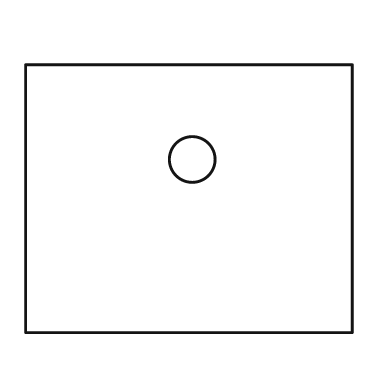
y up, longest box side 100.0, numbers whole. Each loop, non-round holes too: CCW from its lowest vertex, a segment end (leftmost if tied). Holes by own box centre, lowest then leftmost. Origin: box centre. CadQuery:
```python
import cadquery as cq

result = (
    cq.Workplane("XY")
    .moveTo(-50.0, -41.0)
    .lineTo(50.0, -41.0)
    .lineTo(50.0, 41.0)
    .lineTo(-50.0, 41.0)
    .close()
    .moveTo(1.0, 12.0)
    .circle(7.0)
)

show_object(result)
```